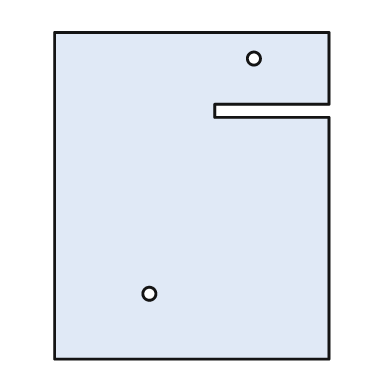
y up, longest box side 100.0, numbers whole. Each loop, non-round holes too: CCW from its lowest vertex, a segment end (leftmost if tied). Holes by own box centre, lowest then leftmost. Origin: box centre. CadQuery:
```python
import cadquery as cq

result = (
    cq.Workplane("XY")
    .moveTo(-42.0, -50.0)
    .lineTo(42.0, -50.0)
    .lineTo(42.0, 24.0)
    .lineTo(7.0, 24.0)
    .lineTo(7.0, 28.0)
    .lineTo(42.0, 28.0)
    .lineTo(42.0, 50.0)
    .lineTo(-42.0, 50.0)
    .close()
    .moveTo(-13.0, -30.0)
    .circle(2.0)
    .moveTo(19.0, 42.0)
    .circle(2.0)
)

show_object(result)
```